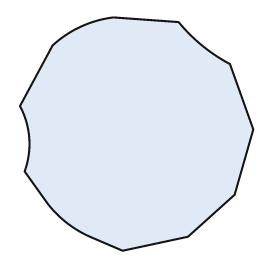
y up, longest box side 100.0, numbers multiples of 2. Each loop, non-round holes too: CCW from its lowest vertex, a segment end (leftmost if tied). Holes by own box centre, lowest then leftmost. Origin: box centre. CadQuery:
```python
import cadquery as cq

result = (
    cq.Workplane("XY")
    .moveTo(-6.0, -50.0)
    .lineTo(22.0, -44.0)
    .lineTo(42.0, -26.0)
    .lineTo(50.0, 2.0)
    .lineTo(40.0, 30.0)
    .threePointArc((28.0, 38.0), (18.0, 48.0))
    .lineTo(-10.0, 50.0)
    .threePointArc((-24.0, 46.0), (-36.0, 38.0))
    .lineTo(-50.0, 12.0)
    .threePointArc((-46.0, -2.0), (-48.0, -16.0))
    .lineTo(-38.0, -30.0)
    .threePointArc((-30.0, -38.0), (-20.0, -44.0))
    .close()
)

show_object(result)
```